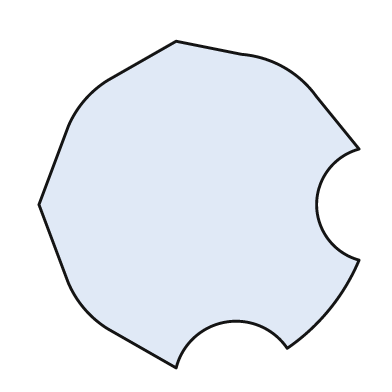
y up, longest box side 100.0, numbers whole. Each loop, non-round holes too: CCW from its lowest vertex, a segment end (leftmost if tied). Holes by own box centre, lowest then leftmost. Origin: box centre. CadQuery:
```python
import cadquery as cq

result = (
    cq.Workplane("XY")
    .moveTo(-7.0, -50.0)
    .threePointArc((8.0, -36.0), (27.0, -44.0))
    .threePointArc((40.0, -32.0), (49.0, -17.0))
    .threePointArc((36.0, 0.0), (49.0, 17.0))
    .lineTo(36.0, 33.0)
    .threePointArc((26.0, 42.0), (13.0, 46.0))
    .lineTo(-7.0, 50.0)
    .lineTo(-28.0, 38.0)
    .threePointArc((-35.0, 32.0), (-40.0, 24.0))
    .lineTo(-49.0, 0.0)
    .lineTo(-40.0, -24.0)
    .threePointArc((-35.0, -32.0), (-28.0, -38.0))
    .close()
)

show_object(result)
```